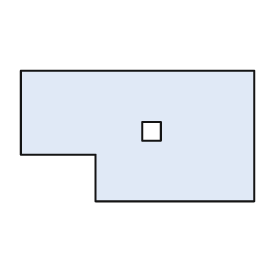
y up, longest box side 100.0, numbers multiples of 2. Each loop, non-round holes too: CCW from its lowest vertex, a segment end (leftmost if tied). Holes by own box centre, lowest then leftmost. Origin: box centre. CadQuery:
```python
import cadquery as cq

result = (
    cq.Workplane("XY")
    .moveTo(-18.0, -28.0)
    .lineTo(50.0, -28.0)
    .lineTo(50.0, 28.0)
    .lineTo(-50.0, 28.0)
    .lineTo(-50.0, -8.0)
    .lineTo(-18.0, -8.0)
    .close()
    .moveTo(2.0, -2.0)
    .lineTo(10.0, -2.0)
    .lineTo(10.0, 6.0)
    .lineTo(2.0, 6.0)
    .close()
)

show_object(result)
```